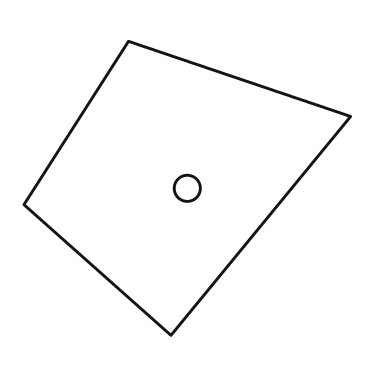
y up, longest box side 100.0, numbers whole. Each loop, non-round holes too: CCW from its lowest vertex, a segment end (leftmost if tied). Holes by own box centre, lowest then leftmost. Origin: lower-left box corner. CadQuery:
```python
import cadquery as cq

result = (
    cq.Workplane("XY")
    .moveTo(45.0, 0.0)
    .lineTo(100.0, 67.0)
    .lineTo(32.0, 90.0)
    .lineTo(0.0, 40.0)
    .close()
    .moveTo(50.0, 45.0)
    .circle(4.0)
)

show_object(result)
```